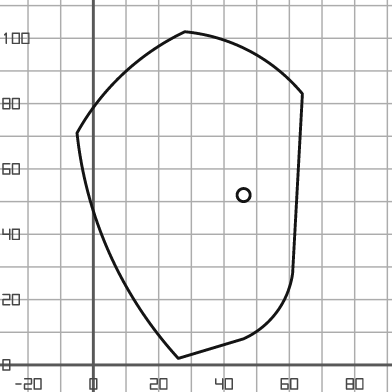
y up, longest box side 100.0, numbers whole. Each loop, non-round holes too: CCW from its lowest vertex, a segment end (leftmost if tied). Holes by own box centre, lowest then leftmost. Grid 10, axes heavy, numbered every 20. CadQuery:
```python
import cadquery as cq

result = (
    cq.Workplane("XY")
    .moveTo(26.0, 2.0)
    .lineTo(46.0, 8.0)
    .threePointArc((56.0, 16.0), (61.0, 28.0))
    .lineTo(64.0, 83.0)
    .threePointArc((48.0, 96.0), (28.0, 102.0))
    .threePointArc((9.0, 89.0), (-5.0, 71.0))
    .threePointArc((5.0, 34.0), (26.0, 2.0))
    .close()
    .moveTo(46.0, 52.0)
    .circle(2.0)
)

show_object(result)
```